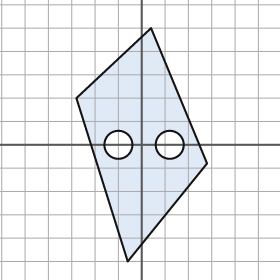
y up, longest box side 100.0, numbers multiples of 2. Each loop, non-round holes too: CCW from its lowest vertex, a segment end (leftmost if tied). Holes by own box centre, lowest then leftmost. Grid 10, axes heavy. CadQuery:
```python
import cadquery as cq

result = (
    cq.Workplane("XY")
    .moveTo(-6.0, -50.0)
    .lineTo(28.0, -8.0)
    .lineTo(4.0, 50.0)
    .lineTo(-28.0, 20.0)
    .close()
    .moveTo(-10.0, 0.0)
    .circle(6.0)
    .moveTo(12.0, 0.0)
    .circle(6.0)
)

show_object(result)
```